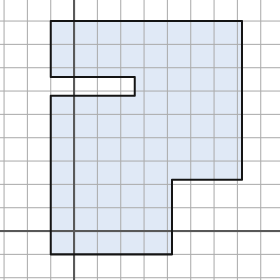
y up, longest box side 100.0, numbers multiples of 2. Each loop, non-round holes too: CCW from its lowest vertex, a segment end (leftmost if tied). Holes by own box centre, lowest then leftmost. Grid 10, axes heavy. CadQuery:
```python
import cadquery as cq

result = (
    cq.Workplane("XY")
    .moveTo(-10.0, -10.0)
    .lineTo(42.0, -10.0)
    .lineTo(42.0, 22.0)
    .lineTo(72.0, 22.0)
    .lineTo(72.0, 90.0)
    .lineTo(-10.0, 90.0)
    .lineTo(-10.0, 66.0)
    .lineTo(26.0, 66.0)
    .lineTo(26.0, 58.0)
    .lineTo(-10.0, 58.0)
    .close()
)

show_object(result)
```